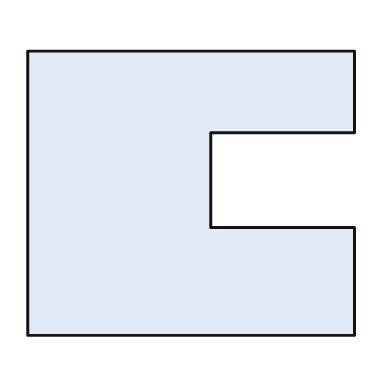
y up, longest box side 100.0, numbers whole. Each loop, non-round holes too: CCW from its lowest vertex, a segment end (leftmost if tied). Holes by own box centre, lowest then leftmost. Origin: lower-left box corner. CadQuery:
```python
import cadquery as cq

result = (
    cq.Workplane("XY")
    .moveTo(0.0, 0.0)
    .lineTo(100.0, 0.0)
    .lineTo(100.0, 33.0)
    .lineTo(56.0, 33.0)
    .lineTo(56.0, 62.0)
    .lineTo(100.0, 62.0)
    .lineTo(100.0, 87.0)
    .lineTo(0.0, 87.0)
    .close()
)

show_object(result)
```